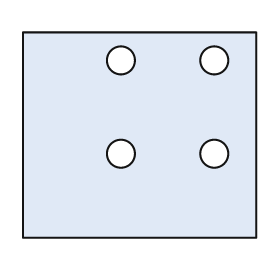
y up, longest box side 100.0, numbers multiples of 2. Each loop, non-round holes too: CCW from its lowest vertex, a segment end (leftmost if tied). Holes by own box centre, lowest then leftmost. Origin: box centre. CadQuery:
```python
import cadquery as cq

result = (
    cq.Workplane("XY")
    .moveTo(-50.0, -44.0)
    .lineTo(50.0, -44.0)
    .lineTo(50.0, 44.0)
    .lineTo(-50.0, 44.0)
    .close()
    .moveTo(-8.0, -8.0)
    .circle(6.0)
    .moveTo(32.0, -8.0)
    .circle(6.0)
    .moveTo(-8.0, 32.0)
    .circle(6.0)
    .moveTo(32.0, 32.0)
    .circle(6.0)
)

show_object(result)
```